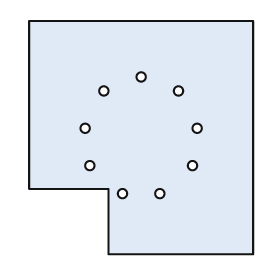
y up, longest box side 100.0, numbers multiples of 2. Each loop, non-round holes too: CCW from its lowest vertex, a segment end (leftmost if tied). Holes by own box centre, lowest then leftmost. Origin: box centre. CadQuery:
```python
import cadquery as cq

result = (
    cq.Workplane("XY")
    .moveTo(-14.0, -50.0)
    .lineTo(48.0, -50.0)
    .lineTo(48.0, 50.0)
    .lineTo(-48.0, 50.0)
    .lineTo(-48.0, -22.0)
    .lineTo(-14.0, -22.0)
    .close()
    .moveTo(-8.0, -24.0)
    .circle(2.0)
    .moveTo(8.0, -24.0)
    .circle(2.0)
    .moveTo(-22.0, -12.0)
    .circle(2.0)
    .moveTo(22.0, -12.0)
    .circle(2.0)
    .moveTo(-24.0, 4.0)
    .circle(2.0)
    .moveTo(24.0, 4.0)
    .circle(2.0)
    .moveTo(-16.0, 20.0)
    .circle(2.0)
    .moveTo(16.0, 20.0)
    .circle(2.0)
    .moveTo(0.0, 26.0)
    .circle(2.0)
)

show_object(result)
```